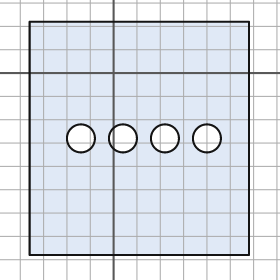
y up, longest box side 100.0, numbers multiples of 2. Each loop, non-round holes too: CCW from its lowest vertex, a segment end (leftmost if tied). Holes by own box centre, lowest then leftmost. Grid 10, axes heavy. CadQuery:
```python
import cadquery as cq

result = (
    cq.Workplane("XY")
    .moveTo(-36.0, -78.0)
    .lineTo(58.0, -78.0)
    .lineTo(58.0, 22.0)
    .lineTo(-36.0, 22.0)
    .close()
    .moveTo(-14.0, -28.0)
    .circle(6.0)
    .moveTo(4.0, -28.0)
    .circle(6.0)
    .moveTo(22.0, -28.0)
    .circle(6.0)
    .moveTo(40.0, -28.0)
    .circle(6.0)
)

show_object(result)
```